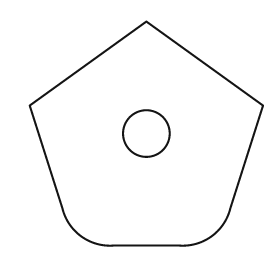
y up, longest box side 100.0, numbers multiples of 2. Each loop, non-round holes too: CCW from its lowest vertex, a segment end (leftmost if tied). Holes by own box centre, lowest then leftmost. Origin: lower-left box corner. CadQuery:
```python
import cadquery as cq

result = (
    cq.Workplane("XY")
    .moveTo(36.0, 0.0)
    .lineTo(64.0, 0.0)
    .threePointArc((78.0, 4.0), (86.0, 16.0))
    .lineTo(100.0, 60.0)
    .lineTo(50.0, 96.0)
    .lineTo(0.0, 60.0)
    .lineTo(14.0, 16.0)
    .threePointArc((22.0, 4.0), (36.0, 0.0))
    .close()
    .moveTo(50.0, 48.0)
    .circle(10.0)
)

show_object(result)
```